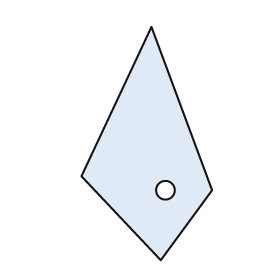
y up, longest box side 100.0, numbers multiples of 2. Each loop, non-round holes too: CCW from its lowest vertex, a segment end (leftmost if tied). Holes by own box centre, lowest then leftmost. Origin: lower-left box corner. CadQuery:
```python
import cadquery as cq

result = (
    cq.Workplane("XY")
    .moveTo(34.0, 0.0)
    .lineTo(56.0, 30.0)
    .lineTo(30.0, 100.0)
    .lineTo(0.0, 36.0)
    .close()
    .moveTo(36.0, 30.0)
    .circle(4.0)
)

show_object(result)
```